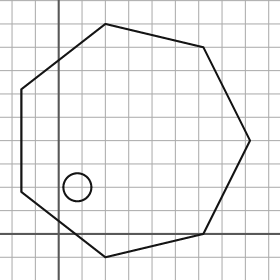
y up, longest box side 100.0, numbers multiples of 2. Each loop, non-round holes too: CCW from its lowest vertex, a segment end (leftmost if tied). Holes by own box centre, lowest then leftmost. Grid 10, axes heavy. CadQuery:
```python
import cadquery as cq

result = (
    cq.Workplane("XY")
    .moveTo(20.0, -10.0)
    .lineTo(62.0, 0.0)
    .lineTo(82.0, 40.0)
    .lineTo(62.0, 80.0)
    .lineTo(20.0, 90.0)
    .lineTo(-16.0, 62.0)
    .lineTo(-16.0, 18.0)
    .close()
    .moveTo(8.0, 20.0)
    .circle(6.0)
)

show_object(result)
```